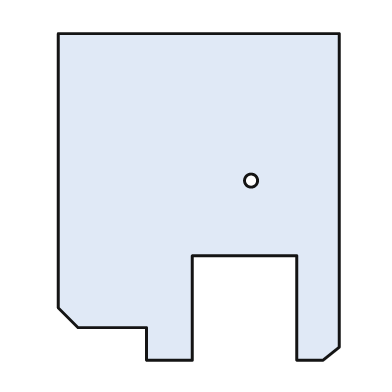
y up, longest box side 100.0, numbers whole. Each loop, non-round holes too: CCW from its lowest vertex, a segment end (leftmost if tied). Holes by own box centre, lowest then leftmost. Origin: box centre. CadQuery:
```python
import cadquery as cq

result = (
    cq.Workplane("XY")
    .moveTo(-16.0, -50.0)
    .lineTo(-2.0, -50.0)
    .lineTo(-2.0, -18.0)
    .lineTo(30.0, -18.0)
    .lineTo(30.0, -50.0)
    .lineTo(38.0, -50.0)
    .lineTo(43.0, -46.0)
    .lineTo(43.0, 50.0)
    .lineTo(-43.0, 50.0)
    .lineTo(-43.0, -34.0)
    .lineTo(-37.0, -40.0)
    .lineTo(-16.0, -40.0)
    .close()
    .moveTo(16.0, 5.0)
    .circle(2.0)
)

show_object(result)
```